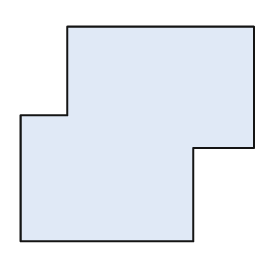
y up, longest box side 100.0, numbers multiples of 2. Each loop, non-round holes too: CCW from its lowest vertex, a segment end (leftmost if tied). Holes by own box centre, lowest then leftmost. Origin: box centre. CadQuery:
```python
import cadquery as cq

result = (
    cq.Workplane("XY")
    .moveTo(-50.0, -46.0)
    .lineTo(24.0, -46.0)
    .lineTo(24.0, -6.0)
    .lineTo(50.0, -6.0)
    .lineTo(50.0, 46.0)
    .lineTo(-30.0, 46.0)
    .lineTo(-30.0, 8.0)
    .lineTo(-50.0, 8.0)
    .close()
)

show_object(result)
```